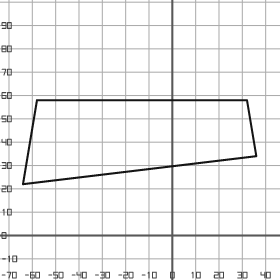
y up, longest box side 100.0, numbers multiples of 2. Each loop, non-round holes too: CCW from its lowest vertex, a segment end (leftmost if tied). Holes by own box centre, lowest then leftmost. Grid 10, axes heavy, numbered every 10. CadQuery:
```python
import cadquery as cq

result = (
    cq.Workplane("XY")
    .moveTo(-64.0, 22.0)
    .lineTo(36.0, 34.0)
    .lineTo(32.0, 58.0)
    .lineTo(-58.0, 58.0)
    .close()
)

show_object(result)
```